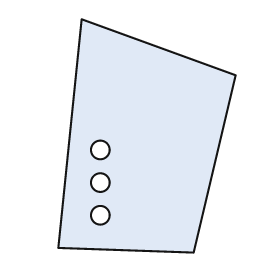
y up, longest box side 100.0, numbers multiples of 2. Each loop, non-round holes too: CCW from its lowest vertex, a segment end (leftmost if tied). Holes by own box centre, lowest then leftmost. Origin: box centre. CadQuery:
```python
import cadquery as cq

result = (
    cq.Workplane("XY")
    .moveTo(20.0, -50.0)
    .lineTo(38.0, 26.0)
    .lineTo(-28.0, 50.0)
    .lineTo(-38.0, -48.0)
    .close()
    .moveTo(-20.0, -34.0)
    .circle(4.0)
    .moveTo(-20.0, -20.0)
    .circle(4.0)
    .moveTo(-20.0, -6.0)
    .circle(4.0)
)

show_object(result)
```